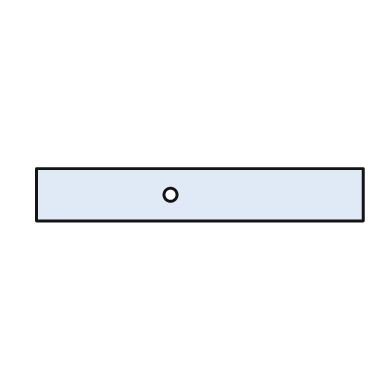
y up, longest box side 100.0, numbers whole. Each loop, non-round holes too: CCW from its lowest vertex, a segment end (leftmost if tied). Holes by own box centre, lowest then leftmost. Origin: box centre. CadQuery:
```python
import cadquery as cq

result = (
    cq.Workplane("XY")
    .moveTo(-50.0, -8.0)
    .lineTo(50.0, -8.0)
    .lineTo(50.0, 8.0)
    .lineTo(-50.0, 8.0)
    .close()
    .moveTo(-9.0, 0.0)
    .circle(2.0)
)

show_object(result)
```